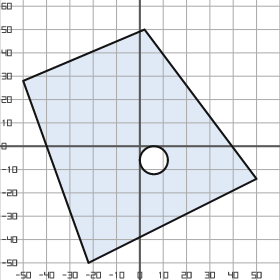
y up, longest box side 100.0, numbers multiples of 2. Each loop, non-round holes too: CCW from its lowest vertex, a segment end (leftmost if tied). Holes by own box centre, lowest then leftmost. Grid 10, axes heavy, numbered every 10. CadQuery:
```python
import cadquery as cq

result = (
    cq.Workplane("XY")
    .moveTo(-22.0, -50.0)
    .lineTo(50.0, -14.0)
    .lineTo(2.0, 50.0)
    .lineTo(-50.0, 28.0)
    .close()
    .moveTo(6.0, -6.0)
    .circle(6.0)
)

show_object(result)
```